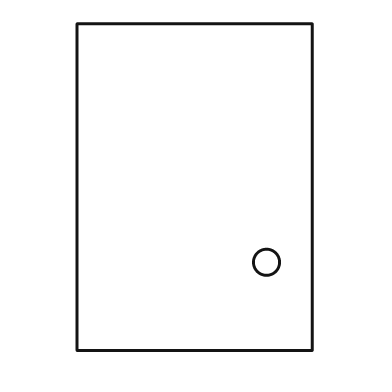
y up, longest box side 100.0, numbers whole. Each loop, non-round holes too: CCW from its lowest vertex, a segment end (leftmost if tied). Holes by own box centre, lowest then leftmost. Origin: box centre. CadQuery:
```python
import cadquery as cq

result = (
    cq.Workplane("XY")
    .moveTo(-36.0, -50.0)
    .lineTo(36.0, -50.0)
    .lineTo(36.0, 50.0)
    .lineTo(-36.0, 50.0)
    .close()
    .moveTo(22.0, -23.0)
    .circle(4.0)
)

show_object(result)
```